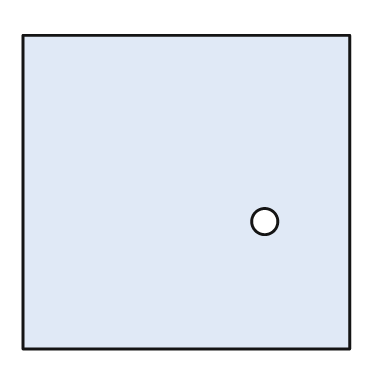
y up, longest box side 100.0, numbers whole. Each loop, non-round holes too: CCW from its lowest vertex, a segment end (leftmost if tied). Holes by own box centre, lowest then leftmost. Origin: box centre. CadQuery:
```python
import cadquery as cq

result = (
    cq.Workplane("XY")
    .moveTo(-50.0, -48.0)
    .lineTo(50.0, -48.0)
    .lineTo(50.0, 48.0)
    .lineTo(-50.0, 48.0)
    .close()
    .moveTo(24.0, -9.0)
    .circle(4.0)
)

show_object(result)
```